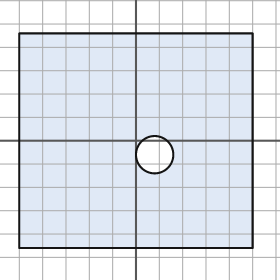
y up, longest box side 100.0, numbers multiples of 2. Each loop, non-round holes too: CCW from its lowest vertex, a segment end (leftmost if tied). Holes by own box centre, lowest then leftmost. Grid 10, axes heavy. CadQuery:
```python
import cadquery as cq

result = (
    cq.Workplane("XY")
    .moveTo(-50.0, -46.0)
    .lineTo(50.0, -46.0)
    .lineTo(50.0, 46.0)
    .lineTo(-50.0, 46.0)
    .close()
    .moveTo(8.0, -6.0)
    .circle(8.0)
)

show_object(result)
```